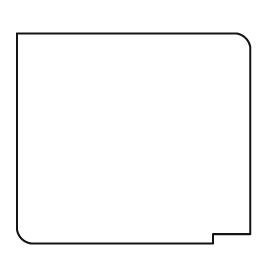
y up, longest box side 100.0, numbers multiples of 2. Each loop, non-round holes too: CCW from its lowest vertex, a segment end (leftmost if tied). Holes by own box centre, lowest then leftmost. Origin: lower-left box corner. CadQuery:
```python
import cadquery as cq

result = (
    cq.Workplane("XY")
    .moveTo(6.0, 0.0)
    .lineTo(84.0, 0.0)
    .lineTo(84.0, 4.0)
    .lineTo(100.0, 4.0)
    .lineTo(100.0, 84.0)
    .threePointArc((98.0, 88.0), (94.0, 90.0))
    .lineTo(0.0, 90.0)
    .lineTo(0.0, 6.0)
    .threePointArc((2.0, 2.0), (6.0, 0.0))
    .close()
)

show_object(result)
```